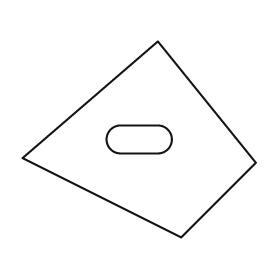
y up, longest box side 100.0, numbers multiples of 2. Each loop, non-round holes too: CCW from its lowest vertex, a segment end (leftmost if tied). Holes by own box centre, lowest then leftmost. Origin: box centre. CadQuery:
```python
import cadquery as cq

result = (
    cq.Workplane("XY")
    .moveTo(18.0, -42.0)
    .lineTo(50.0, -10.0)
    .lineTo(8.0, 42.0)
    .lineTo(-50.0, -8.0)
    .close()
    .moveTo(-8.0, -6.0)
    .lineTo(8.0, -6.0)
    .threePointArc((14.0, 0.0), (8.0, 6.0))
    .lineTo(-8.0, 6.0)
    .threePointArc((-14.0, 0.0), (-8.0, -6.0))
    .close()
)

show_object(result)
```